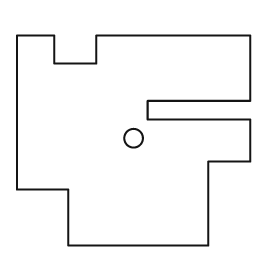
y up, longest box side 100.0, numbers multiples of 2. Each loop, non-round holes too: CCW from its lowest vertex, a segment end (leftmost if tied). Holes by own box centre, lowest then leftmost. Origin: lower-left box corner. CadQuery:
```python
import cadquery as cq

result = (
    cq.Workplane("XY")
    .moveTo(22.0, 0.0)
    .lineTo(82.0, 0.0)
    .lineTo(82.0, 36.0)
    .lineTo(100.0, 36.0)
    .lineTo(100.0, 54.0)
    .lineTo(56.0, 54.0)
    .lineTo(56.0, 62.0)
    .lineTo(100.0, 62.0)
    .lineTo(100.0, 90.0)
    .lineTo(34.0, 90.0)
    .lineTo(34.0, 78.0)
    .lineTo(16.0, 78.0)
    .lineTo(16.0, 90.0)
    .lineTo(0.0, 90.0)
    .lineTo(0.0, 24.0)
    .lineTo(22.0, 24.0)
    .close()
    .moveTo(50.0, 46.0)
    .circle(4.0)
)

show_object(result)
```